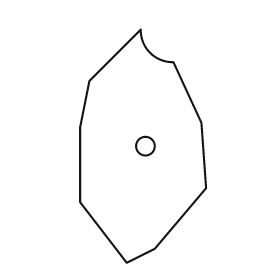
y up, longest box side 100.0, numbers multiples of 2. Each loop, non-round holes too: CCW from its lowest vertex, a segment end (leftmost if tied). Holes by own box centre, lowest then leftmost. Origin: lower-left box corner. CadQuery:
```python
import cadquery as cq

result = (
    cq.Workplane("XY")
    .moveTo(20.0, 0.0)
    .lineTo(32.0, 6.0)
    .lineTo(54.0, 32.0)
    .lineTo(52.0, 60.0)
    .lineTo(40.0, 86.0)
    .threePointArc((30.0, 90.0), (26.0, 100.0))
    .lineTo(4.0, 78.0)
    .lineTo(0.0, 58.0)
    .lineTo(0.0, 26.0)
    .close()
    .moveTo(28.0, 50.0)
    .circle(4.0)
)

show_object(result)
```